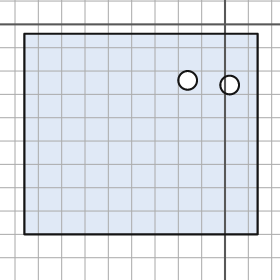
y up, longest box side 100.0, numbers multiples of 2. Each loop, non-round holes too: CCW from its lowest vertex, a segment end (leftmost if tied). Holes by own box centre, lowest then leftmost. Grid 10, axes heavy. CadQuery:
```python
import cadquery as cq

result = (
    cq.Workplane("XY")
    .moveTo(-86.0, -90.0)
    .lineTo(14.0, -90.0)
    .lineTo(14.0, -4.0)
    .lineTo(-86.0, -4.0)
    .close()
    .moveTo(2.0, -26.0)
    .circle(4.0)
    .moveTo(-16.0, -24.0)
    .circle(4.0)
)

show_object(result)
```